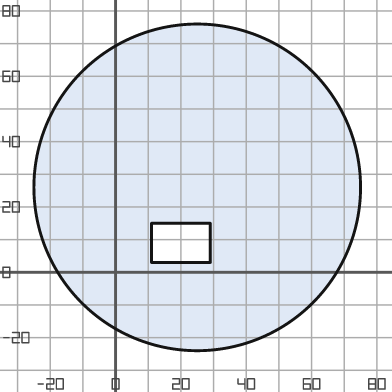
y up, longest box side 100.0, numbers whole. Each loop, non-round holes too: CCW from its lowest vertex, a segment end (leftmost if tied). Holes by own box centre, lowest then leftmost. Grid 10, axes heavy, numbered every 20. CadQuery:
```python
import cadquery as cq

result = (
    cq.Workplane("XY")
    .moveTo(25.0, 26.0)
    .circle(50.0)
    .moveTo(11.0, 3.0)
    .lineTo(29.0, 3.0)
    .lineTo(29.0, 15.0)
    .lineTo(11.0, 15.0)
    .close()
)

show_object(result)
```